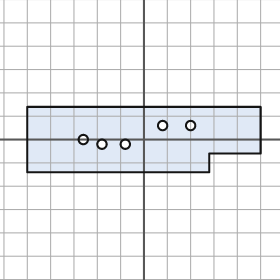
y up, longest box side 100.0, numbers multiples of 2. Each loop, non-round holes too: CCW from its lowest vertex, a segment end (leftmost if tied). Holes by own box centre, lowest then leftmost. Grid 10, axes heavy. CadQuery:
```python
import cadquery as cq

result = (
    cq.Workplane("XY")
    .moveTo(-50.0, -14.0)
    .lineTo(28.0, -14.0)
    .lineTo(28.0, -6.0)
    .lineTo(50.0, -6.0)
    .lineTo(50.0, 14.0)
    .lineTo(-50.0, 14.0)
    .close()
    .moveTo(-18.0, -2.0)
    .circle(2.0)
    .moveTo(-8.0, -2.0)
    .circle(2.0)
    .moveTo(-26.0, 0.0)
    .circle(2.0)
    .moveTo(8.0, 6.0)
    .circle(2.0)
    .moveTo(20.0, 6.0)
    .circle(2.0)
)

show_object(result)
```